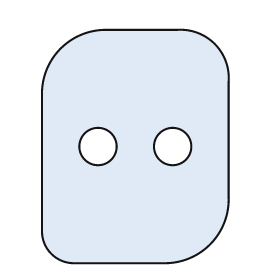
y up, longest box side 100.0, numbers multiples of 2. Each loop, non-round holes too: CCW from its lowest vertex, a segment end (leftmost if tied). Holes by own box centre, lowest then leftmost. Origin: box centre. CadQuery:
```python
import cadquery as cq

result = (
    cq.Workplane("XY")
    .moveTo(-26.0, -50.0)
    .lineTo(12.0, -50.0)
    .threePointArc((32.0, -42.0), (40.0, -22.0))
    .lineTo(40.0, 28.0)
    .threePointArc((34.0, 44.0), (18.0, 50.0))
    .lineTo(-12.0, 50.0)
    .threePointArc((-32.0, 42.0), (-40.0, 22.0))
    .lineTo(-40.0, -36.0)
    .threePointArc((-36.0, -46.0), (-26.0, -50.0))
    .close()
    .moveTo(-16.0, 0.0)
    .circle(8.0)
    .moveTo(16.0, 0.0)
    .circle(8.0)
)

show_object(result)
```